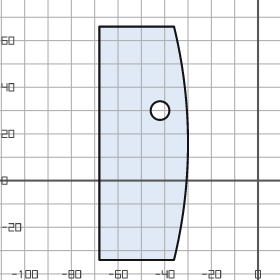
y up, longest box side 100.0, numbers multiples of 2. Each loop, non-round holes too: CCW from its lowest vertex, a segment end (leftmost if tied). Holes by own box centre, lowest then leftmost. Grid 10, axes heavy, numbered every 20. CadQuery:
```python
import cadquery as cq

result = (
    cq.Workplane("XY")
    .moveTo(-68.0, -34.0)
    .lineTo(-36.0, -34.0)
    .threePointArc((-30.0, 16.0), (-36.0, 66.0))
    .lineTo(-68.0, 66.0)
    .close()
    .moveTo(-42.0, 30.0)
    .circle(4.0)
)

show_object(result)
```